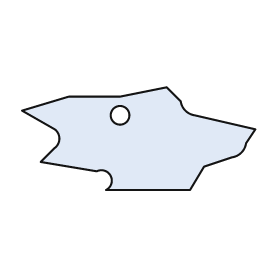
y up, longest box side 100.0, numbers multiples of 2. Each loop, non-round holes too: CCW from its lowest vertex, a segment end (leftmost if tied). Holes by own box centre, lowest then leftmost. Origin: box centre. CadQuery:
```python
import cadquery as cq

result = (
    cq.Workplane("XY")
    .moveTo(-14.0, -22.0)
    .lineTo(22.0, -22.0)
    .lineTo(28.0, -12.0)
    .lineTo(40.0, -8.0)
    .threePointArc((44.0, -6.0), (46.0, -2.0))
    .lineTo(50.0, 4.0)
    .lineTo(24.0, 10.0)
    .threePointArc((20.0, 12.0), (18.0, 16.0))
    .lineTo(12.0, 22.0)
    .lineTo(-8.0, 18.0)
    .lineTo(-30.0, 18.0)
    .lineTo(-50.0, 12.0)
    .lineTo(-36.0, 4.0)
    .threePointArc((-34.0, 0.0), (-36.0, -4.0))
    .lineTo(-42.0, -10.0)
    .lineTo(-18.0, -14.0)
    .threePointArc((-12.0, -16.0), (-14.0, -22.0))
    .close()
    .moveTo(-8.0, 10.0)
    .circle(4.0)
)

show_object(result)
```